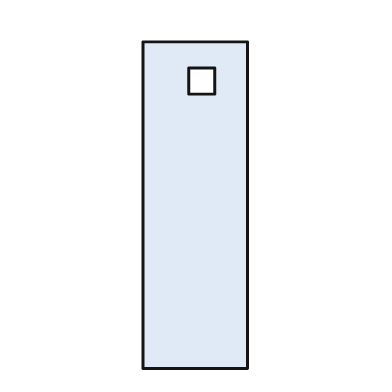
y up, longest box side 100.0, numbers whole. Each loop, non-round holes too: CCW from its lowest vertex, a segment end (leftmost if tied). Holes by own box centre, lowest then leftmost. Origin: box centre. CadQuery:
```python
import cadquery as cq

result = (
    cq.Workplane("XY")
    .moveTo(-16.0, -50.0)
    .lineTo(16.0, -50.0)
    .lineTo(16.0, 50.0)
    .lineTo(-16.0, 50.0)
    .close()
    .moveTo(-2.0, 34.0)
    .lineTo(6.0, 34.0)
    .lineTo(6.0, 42.0)
    .lineTo(-2.0, 42.0)
    .close()
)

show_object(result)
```